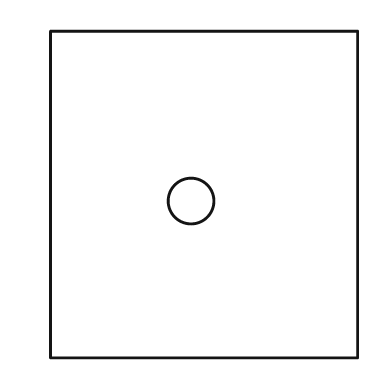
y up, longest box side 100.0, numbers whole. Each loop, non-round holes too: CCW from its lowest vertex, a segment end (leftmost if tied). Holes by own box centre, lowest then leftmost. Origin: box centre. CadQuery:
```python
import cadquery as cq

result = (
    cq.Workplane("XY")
    .moveTo(-47.0, -50.0)
    .lineTo(47.0, -50.0)
    .lineTo(47.0, 50.0)
    .lineTo(-47.0, 50.0)
    .close()
    .moveTo(-4.0, -2.0)
    .circle(7.0)
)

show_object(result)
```